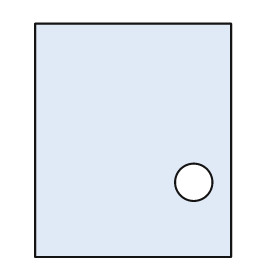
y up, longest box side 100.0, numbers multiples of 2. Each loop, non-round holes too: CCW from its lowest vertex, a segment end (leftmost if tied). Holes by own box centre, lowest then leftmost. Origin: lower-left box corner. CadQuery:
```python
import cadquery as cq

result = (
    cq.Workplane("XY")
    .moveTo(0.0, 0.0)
    .lineTo(84.0, 0.0)
    .lineTo(84.0, 100.0)
    .lineTo(0.0, 100.0)
    .close()
    .moveTo(68.0, 32.0)
    .circle(8.0)
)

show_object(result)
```